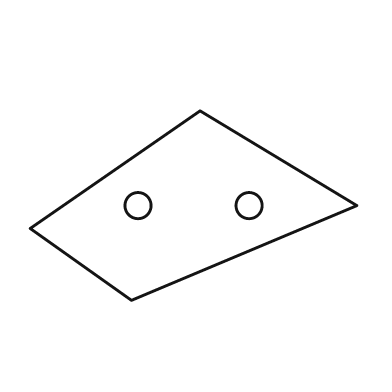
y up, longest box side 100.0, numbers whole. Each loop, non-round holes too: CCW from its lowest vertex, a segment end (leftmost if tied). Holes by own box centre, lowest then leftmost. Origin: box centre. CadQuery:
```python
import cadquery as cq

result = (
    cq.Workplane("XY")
    .moveTo(-19.0, -29.0)
    .lineTo(50.0, 0.0)
    .lineTo(2.0, 29.0)
    .lineTo(-50.0, -7.0)
    .close()
    .moveTo(-17.0, 0.0)
    .circle(4.0)
    .moveTo(17.0, 0.0)
    .circle(4.0)
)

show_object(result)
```